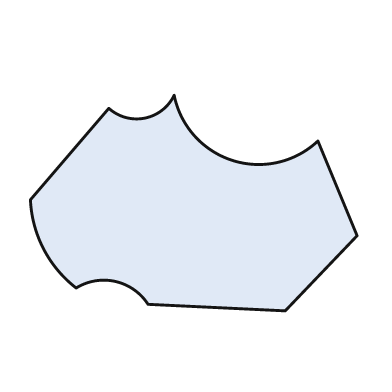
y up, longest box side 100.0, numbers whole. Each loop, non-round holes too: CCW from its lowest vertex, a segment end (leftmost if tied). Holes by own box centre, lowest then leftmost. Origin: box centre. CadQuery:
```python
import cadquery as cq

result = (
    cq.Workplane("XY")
    .moveTo(28.0, -33.0)
    .lineTo(50.0, -10.0)
    .lineTo(38.0, 19.0)
    .threePointArc((12.0, 13.0), (-6.0, 33.0))
    .threePointArc((-15.0, 26.0), (-26.0, 29.0))
    .lineTo(-50.0, 1.0)
    .threePointArc((-46.0, -14.0), (-36.0, -26.0))
    .threePointArc((-24.0, -24.0), (-14.0, -31.0))
    .close()
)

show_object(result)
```